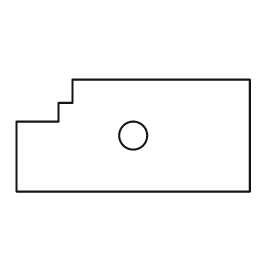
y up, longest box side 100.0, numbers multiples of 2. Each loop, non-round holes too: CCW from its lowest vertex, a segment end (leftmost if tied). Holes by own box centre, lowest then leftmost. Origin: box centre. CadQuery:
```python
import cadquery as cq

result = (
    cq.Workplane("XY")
    .moveTo(-50.0, -24.0)
    .lineTo(50.0, -24.0)
    .lineTo(50.0, 24.0)
    .lineTo(-26.0, 24.0)
    .lineTo(-26.0, 14.0)
    .lineTo(-32.0, 14.0)
    .lineTo(-32.0, 6.0)
    .lineTo(-50.0, 6.0)
    .close()
    .moveTo(0.0, 0.0)
    .circle(6.0)
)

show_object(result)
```